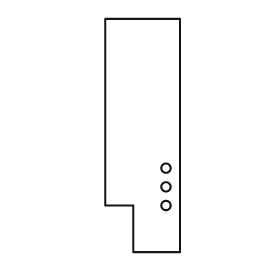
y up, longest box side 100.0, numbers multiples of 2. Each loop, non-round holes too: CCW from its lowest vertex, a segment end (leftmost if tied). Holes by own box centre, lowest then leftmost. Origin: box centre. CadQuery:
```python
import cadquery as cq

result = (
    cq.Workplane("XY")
    .moveTo(-4.0, -50.0)
    .lineTo(16.0, -50.0)
    .lineTo(16.0, 50.0)
    .lineTo(-16.0, 50.0)
    .lineTo(-16.0, -30.0)
    .lineTo(-4.0, -30.0)
    .close()
    .moveTo(10.0, -30.0)
    .circle(2.0)
    .moveTo(10.0, -22.0)
    .circle(2.0)
    .moveTo(10.0, -14.0)
    .circle(2.0)
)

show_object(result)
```